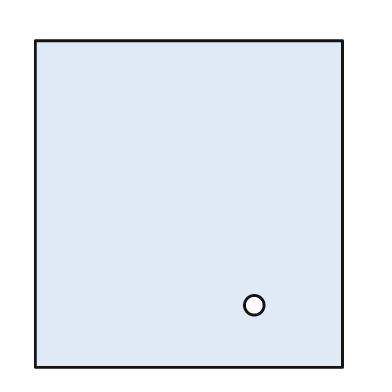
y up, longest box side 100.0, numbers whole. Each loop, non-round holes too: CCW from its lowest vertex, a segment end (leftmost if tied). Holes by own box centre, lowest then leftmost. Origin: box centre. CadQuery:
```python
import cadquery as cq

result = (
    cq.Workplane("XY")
    .moveTo(-47.0, -50.0)
    .lineTo(47.0, -50.0)
    .lineTo(47.0, 50.0)
    .lineTo(-47.0, 50.0)
    .close()
    .moveTo(20.0, -31.0)
    .circle(3.0)
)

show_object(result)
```